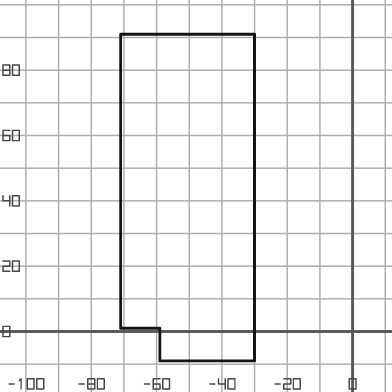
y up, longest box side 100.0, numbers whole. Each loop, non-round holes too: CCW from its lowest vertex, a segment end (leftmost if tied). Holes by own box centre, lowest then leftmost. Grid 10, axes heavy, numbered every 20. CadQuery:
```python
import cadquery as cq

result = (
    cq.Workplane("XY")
    .moveTo(-59.0, -9.0)
    .lineTo(-30.0, -9.0)
    .lineTo(-30.0, 91.0)
    .lineTo(-71.0, 91.0)
    .lineTo(-71.0, 1.0)
    .lineTo(-59.0, 1.0)
    .close()
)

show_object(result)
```